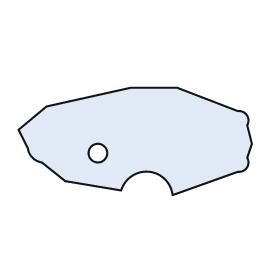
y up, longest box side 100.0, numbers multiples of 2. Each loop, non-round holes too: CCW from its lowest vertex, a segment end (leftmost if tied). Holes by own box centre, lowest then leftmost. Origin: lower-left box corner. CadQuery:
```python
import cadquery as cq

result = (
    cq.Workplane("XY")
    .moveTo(66.0, 0.0)
    .lineTo(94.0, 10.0)
    .threePointArc((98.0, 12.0), (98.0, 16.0))
    .lineTo(100.0, 22.0)
    .lineTo(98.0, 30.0)
    .threePointArc((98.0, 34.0), (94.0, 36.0))
    .lineTo(68.0, 46.0)
    .lineTo(48.0, 46.0)
    .lineTo(12.0, 38.0)
    .lineTo(0.0, 28.0)
    .lineTo(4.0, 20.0)
    .threePointArc((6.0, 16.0), (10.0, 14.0))
    .lineTo(20.0, 6.0)
    .lineTo(44.0, 2.0)
    .threePointArc((56.0, 10.0), (66.0, 0.0))
    .close()
    .moveTo(34.0, 18.0)
    .circle(4.0)
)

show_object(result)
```